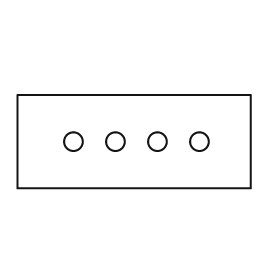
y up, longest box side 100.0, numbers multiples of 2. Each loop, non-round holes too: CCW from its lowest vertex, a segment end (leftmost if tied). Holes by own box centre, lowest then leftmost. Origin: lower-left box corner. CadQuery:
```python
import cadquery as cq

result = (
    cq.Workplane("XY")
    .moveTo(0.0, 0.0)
    .lineTo(100.0, 0.0)
    .lineTo(100.0, 40.0)
    .lineTo(0.0, 40.0)
    .close()
    .moveTo(24.0, 20.0)
    .circle(4.0)
    .moveTo(42.0, 20.0)
    .circle(4.0)
    .moveTo(60.0, 20.0)
    .circle(4.0)
    .moveTo(78.0, 20.0)
    .circle(4.0)
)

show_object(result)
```